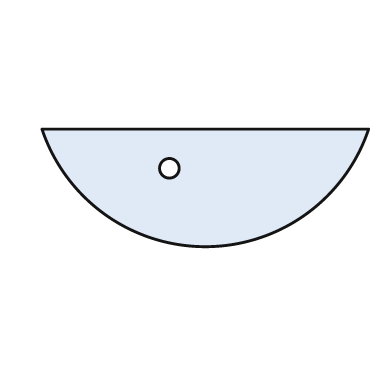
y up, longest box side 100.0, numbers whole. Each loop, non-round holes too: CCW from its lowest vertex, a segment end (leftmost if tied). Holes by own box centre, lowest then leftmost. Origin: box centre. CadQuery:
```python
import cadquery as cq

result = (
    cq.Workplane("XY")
    .moveTo(-50.0, 18.0)
    .threePointArc((0.0, -18.0), (50.0, 18.0))
    .close()
    .moveTo(-11.0, 6.0)
    .circle(3.0)
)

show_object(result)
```